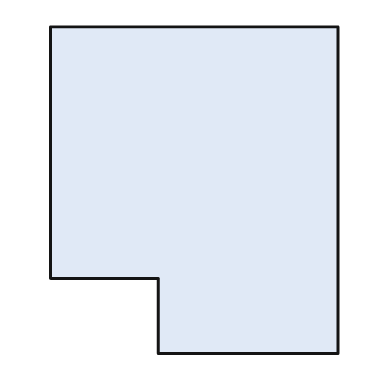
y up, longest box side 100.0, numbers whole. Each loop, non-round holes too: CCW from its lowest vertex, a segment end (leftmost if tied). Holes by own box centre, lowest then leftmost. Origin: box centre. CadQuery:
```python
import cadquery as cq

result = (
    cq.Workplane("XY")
    .moveTo(-11.0, -50.0)
    .lineTo(44.0, -50.0)
    .lineTo(44.0, 50.0)
    .lineTo(-44.0, 50.0)
    .lineTo(-44.0, -27.0)
    .lineTo(-11.0, -27.0)
    .close()
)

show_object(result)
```